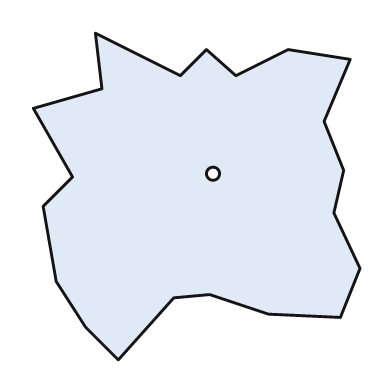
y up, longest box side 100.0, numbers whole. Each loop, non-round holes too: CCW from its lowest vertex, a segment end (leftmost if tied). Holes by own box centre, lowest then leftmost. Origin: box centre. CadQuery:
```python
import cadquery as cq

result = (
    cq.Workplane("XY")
    .moveTo(-24.0, -50.0)
    .lineTo(-7.0, -31.0)
    .lineTo(4.0, -30.0)
    .lineTo(22.0, -36.0)
    .lineTo(44.0, -37.0)
    .lineTo(50.0, -22.0)
    .lineTo(42.0, -5.0)
    .lineTo(45.0, 8.0)
    .lineTo(39.0, 23.0)
    .lineTo(47.0, 42.0)
    .lineTo(28.0, 45.0)
    .lineTo(12.0, 37.0)
    .lineTo(3.0, 45.0)
    .lineTo(-5.0, 37.0)
    .lineTo(-31.0, 50.0)
    .lineTo(-29.0, 33.0)
    .lineTo(-50.0, 27.0)
    .lineTo(-38.0, 6.0)
    .lineTo(-47.0, -3.0)
    .lineTo(-43.0, -26.0)
    .lineTo(-34.0, -40.0)
    .close()
    .moveTo(5.0, 7.0)
    .circle(2.0)
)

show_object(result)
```